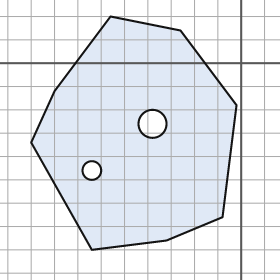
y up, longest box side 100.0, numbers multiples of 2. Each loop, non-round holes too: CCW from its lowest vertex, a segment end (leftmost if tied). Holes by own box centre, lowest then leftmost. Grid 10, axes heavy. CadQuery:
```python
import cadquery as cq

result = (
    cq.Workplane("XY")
    .moveTo(-64.0, -80.0)
    .lineTo(-32.0, -76.0)
    .lineTo(-8.0, -66.0)
    .lineTo(-2.0, -18.0)
    .lineTo(-26.0, 14.0)
    .lineTo(-56.0, 20.0)
    .lineTo(-80.0, -12.0)
    .lineTo(-90.0, -34.0)
    .close()
    .moveTo(-64.0, -46.0)
    .circle(4.0)
    .moveTo(-38.0, -26.0)
    .circle(6.0)
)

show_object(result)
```